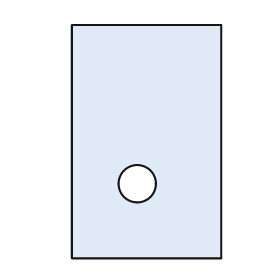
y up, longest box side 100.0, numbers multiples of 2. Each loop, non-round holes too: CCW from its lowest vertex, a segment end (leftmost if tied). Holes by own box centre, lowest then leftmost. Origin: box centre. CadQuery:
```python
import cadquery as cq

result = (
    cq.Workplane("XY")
    .moveTo(-32.0, -50.0)
    .lineTo(32.0, -50.0)
    .lineTo(32.0, 50.0)
    .lineTo(-32.0, 50.0)
    .close()
    .moveTo(-4.0, -18.0)
    .circle(8.0)
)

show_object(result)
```